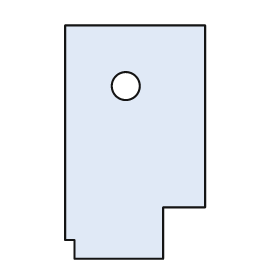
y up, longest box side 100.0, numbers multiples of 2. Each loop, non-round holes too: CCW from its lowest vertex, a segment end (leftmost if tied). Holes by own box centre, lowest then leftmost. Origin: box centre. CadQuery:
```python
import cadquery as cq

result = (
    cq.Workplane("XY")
    .moveTo(-26.0, -50.0)
    .lineTo(12.0, -50.0)
    .lineTo(12.0, -28.0)
    .lineTo(30.0, -28.0)
    .lineTo(30.0, 50.0)
    .lineTo(-30.0, 50.0)
    .lineTo(-30.0, -42.0)
    .lineTo(-26.0, -42.0)
    .close()
    .moveTo(-4.0, 24.0)
    .circle(6.0)
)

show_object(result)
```